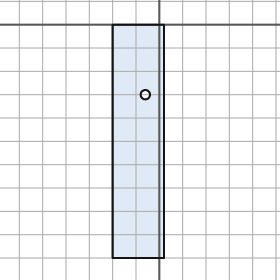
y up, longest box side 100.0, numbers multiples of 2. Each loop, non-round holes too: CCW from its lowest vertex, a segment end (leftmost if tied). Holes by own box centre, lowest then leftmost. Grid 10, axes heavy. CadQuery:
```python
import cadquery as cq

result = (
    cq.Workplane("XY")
    .moveTo(-20.0, -100.0)
    .lineTo(2.0, -100.0)
    .lineTo(2.0, 0.0)
    .lineTo(-20.0, 0.0)
    .close()
    .moveTo(-6.0, -30.0)
    .circle(2.0)
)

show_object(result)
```